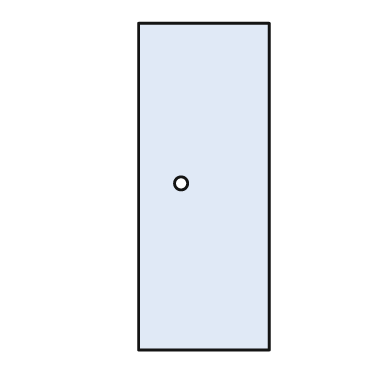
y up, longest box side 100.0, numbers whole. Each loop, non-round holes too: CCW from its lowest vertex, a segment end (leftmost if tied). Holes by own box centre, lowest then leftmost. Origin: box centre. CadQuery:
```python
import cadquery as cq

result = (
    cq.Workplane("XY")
    .moveTo(-20.0, -50.0)
    .lineTo(20.0, -50.0)
    .lineTo(20.0, 50.0)
    .lineTo(-20.0, 50.0)
    .close()
    .moveTo(-7.0, 1.0)
    .circle(2.0)
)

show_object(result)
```